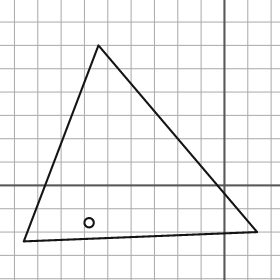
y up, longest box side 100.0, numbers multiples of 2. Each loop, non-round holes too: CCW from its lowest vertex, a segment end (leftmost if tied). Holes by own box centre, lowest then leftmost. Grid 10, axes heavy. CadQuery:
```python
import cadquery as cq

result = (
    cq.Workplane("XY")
    .moveTo(-86.0, -24.0)
    .lineTo(14.0, -20.0)
    .lineTo(-54.0, 60.0)
    .close()
    .moveTo(-58.0, -16.0)
    .circle(2.0)
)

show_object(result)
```